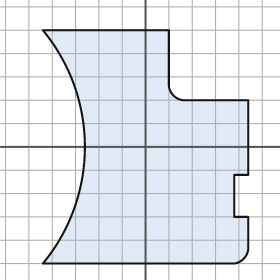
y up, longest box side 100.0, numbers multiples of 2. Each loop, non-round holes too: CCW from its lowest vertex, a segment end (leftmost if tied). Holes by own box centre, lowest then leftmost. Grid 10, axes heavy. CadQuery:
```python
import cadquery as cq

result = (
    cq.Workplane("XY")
    .moveTo(-44.0, -50.0)
    .lineTo(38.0, -50.0)
    .threePointArc((42.0, -48.0), (44.0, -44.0))
    .lineTo(44.0, -30.0)
    .lineTo(38.0, -30.0)
    .lineTo(38.0, -12.0)
    .lineTo(44.0, -12.0)
    .lineTo(44.0, 20.0)
    .lineTo(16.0, 20.0)
    .threePointArc((12.0, 22.0), (10.0, 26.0))
    .lineTo(10.0, 50.0)
    .lineTo(-44.0, 50.0)
    .threePointArc((-26.0, 0.0), (-44.0, -50.0))
    .close()
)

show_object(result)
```